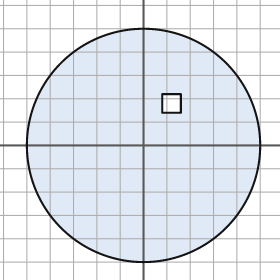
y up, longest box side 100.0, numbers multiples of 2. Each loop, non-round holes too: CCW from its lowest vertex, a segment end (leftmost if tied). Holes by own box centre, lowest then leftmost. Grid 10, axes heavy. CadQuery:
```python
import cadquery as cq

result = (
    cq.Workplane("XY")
    .moveTo(0.0, 0.0)
    .circle(50.0)
    .moveTo(8.0, 14.0)
    .lineTo(16.0, 14.0)
    .lineTo(16.0, 22.0)
    .lineTo(8.0, 22.0)
    .close()
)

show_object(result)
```